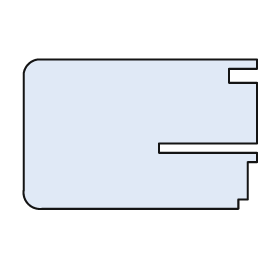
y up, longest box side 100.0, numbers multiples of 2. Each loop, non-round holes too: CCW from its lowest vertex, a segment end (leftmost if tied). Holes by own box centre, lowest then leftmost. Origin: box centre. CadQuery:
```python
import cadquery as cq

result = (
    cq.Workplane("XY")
    .moveTo(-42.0, -32.0)
    .lineTo(42.0, -32.0)
    .lineTo(42.0, -28.0)
    .lineTo(46.0, -28.0)
    .lineTo(46.0, -12.0)
    .lineTo(50.0, -12.0)
    .lineTo(50.0, -8.0)
    .lineTo(8.0, -8.0)
    .lineTo(8.0, -4.0)
    .lineTo(50.0, -4.0)
    .lineTo(50.0, 22.0)
    .lineTo(38.0, 22.0)
    .lineTo(38.0, 28.0)
    .lineTo(50.0, 28.0)
    .lineTo(50.0, 32.0)
    .lineTo(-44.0, 32.0)
    .threePointArc((-48.0, 30.0), (-50.0, 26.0))
    .lineTo(-50.0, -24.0)
    .threePointArc((-48.0, -30.0), (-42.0, -32.0))
    .close()
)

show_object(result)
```